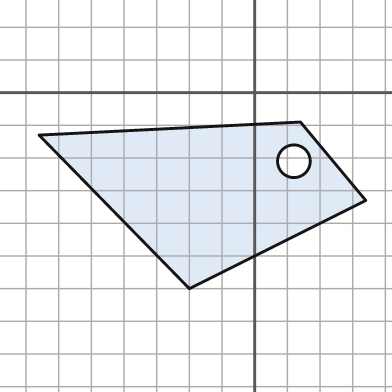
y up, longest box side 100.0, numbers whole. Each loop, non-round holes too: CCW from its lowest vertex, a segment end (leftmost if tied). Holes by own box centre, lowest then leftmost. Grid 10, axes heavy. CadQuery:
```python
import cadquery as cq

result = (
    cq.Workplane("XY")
    .moveTo(-20.0, -60.0)
    .lineTo(34.0, -33.0)
    .lineTo(14.0, -9.0)
    .lineTo(-66.0, -13.0)
    .close()
    .moveTo(12.0, -21.0)
    .circle(5.0)
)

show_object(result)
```